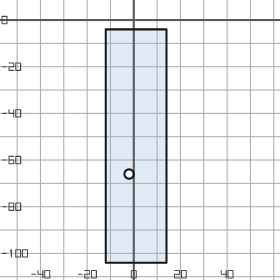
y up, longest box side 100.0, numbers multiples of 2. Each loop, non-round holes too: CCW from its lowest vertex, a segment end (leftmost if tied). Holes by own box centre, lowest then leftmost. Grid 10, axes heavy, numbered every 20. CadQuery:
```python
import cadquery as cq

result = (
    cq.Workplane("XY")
    .moveTo(-12.0, -104.0)
    .lineTo(14.0, -104.0)
    .lineTo(14.0, -4.0)
    .lineTo(-12.0, -4.0)
    .close()
    .moveTo(-2.0, -66.0)
    .circle(2.0)
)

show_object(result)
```